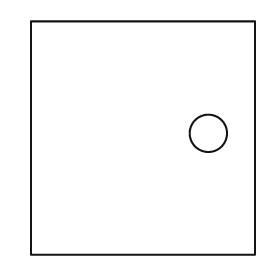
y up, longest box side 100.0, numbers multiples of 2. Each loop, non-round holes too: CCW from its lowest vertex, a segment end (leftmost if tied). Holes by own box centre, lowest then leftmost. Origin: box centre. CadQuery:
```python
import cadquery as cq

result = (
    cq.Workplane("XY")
    .moveTo(-48.0, -50.0)
    .lineTo(48.0, -50.0)
    .lineTo(48.0, 50.0)
    .lineTo(-48.0, 50.0)
    .close()
    .moveTo(28.0, 2.0)
    .circle(8.0)
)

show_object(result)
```